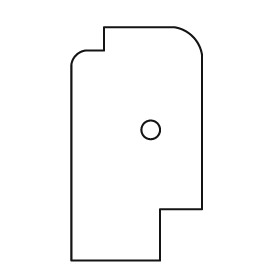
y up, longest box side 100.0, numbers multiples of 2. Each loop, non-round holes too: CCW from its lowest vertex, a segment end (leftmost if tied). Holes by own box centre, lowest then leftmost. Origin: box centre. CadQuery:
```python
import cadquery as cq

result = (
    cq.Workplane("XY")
    .moveTo(-28.0, -50.0)
    .lineTo(10.0, -50.0)
    .lineTo(10.0, -28.0)
    .lineTo(28.0, -28.0)
    .lineTo(28.0, 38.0)
    .threePointArc((24.0, 46.0), (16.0, 50.0))
    .lineTo(-14.0, 50.0)
    .lineTo(-14.0, 40.0)
    .lineTo(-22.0, 40.0)
    .threePointArc((-26.0, 38.0), (-28.0, 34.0))
    .close()
    .moveTo(6.0, 6.0)
    .circle(4.0)
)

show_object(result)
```